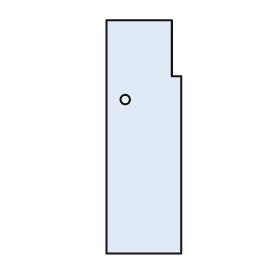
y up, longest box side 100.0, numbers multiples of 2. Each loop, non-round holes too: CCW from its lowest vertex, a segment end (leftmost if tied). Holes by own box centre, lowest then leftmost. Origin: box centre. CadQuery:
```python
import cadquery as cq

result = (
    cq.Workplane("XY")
    .moveTo(-16.0, -50.0)
    .lineTo(16.0, -50.0)
    .lineTo(16.0, 26.0)
    .lineTo(12.0, 26.0)
    .lineTo(12.0, 50.0)
    .lineTo(-16.0, 50.0)
    .close()
    .moveTo(-8.0, 16.0)
    .circle(2.0)
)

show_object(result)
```